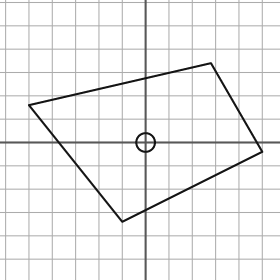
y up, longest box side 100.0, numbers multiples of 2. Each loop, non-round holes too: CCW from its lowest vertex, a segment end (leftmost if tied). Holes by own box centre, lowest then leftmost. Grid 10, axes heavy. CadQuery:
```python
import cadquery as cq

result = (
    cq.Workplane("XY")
    .moveTo(-10.0, -34.0)
    .lineTo(50.0, -4.0)
    .lineTo(28.0, 34.0)
    .lineTo(-50.0, 16.0)
    .close()
    .moveTo(0.0, 0.0)
    .circle(4.0)
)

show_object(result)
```